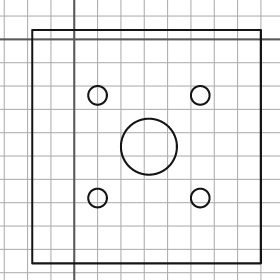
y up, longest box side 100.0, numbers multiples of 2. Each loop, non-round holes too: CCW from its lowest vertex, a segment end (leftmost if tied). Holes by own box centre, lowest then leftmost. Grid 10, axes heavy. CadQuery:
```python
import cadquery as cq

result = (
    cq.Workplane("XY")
    .moveTo(-18.0, -96.0)
    .lineTo(80.0, -96.0)
    .lineTo(80.0, 4.0)
    .lineTo(-18.0, 4.0)
    .close()
    .moveTo(10.0, -68.0)
    .circle(4.0)
    .moveTo(54.0, -68.0)
    .circle(4.0)
    .moveTo(32.0, -46.0)
    .circle(12.0)
    .moveTo(10.0, -24.0)
    .circle(4.0)
    .moveTo(54.0, -24.0)
    .circle(4.0)
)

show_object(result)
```